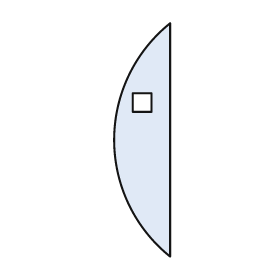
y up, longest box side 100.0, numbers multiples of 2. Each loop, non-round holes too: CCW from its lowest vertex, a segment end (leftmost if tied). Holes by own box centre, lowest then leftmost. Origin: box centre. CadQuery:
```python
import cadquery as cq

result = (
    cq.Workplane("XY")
    .moveTo(12.0, -50.0)
    .lineTo(12.0, 50.0)
    .threePointArc((-12.0, 0.0), (12.0, -50.0))
    .close()
    .moveTo(-4.0, 12.0)
    .lineTo(4.0, 12.0)
    .lineTo(4.0, 20.0)
    .lineTo(-4.0, 20.0)
    .close()
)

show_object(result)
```